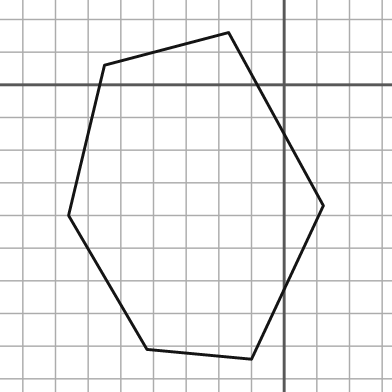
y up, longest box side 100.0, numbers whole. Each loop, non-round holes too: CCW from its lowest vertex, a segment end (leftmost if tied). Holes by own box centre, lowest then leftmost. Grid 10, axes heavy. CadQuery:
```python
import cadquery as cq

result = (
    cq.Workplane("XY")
    .moveTo(-10.0, -84.0)
    .lineTo(12.0, -37.0)
    .lineTo(-17.0, 16.0)
    .lineTo(-55.0, 6.0)
    .lineTo(-66.0, -40.0)
    .lineTo(-42.0, -81.0)
    .close()
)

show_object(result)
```